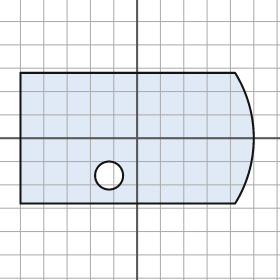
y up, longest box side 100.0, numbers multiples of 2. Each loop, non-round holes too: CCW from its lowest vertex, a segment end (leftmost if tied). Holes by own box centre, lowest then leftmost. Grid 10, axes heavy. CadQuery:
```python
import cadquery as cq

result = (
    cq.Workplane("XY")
    .moveTo(-50.0, -28.0)
    .lineTo(42.0, -28.0)
    .threePointArc((50.0, 0.0), (42.0, 28.0))
    .lineTo(-50.0, 28.0)
    .close()
    .moveTo(-12.0, -16.0)
    .circle(6.0)
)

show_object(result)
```